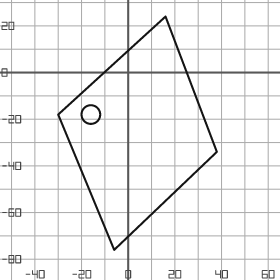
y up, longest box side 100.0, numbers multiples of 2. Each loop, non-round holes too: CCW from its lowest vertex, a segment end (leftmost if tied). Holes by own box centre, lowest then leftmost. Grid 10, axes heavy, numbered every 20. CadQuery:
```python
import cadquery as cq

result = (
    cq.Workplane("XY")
    .moveTo(-6.0, -76.0)
    .lineTo(38.0, -34.0)
    .lineTo(16.0, 24.0)
    .lineTo(-30.0, -18.0)
    .close()
    .moveTo(-16.0, -18.0)
    .circle(4.0)
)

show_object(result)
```